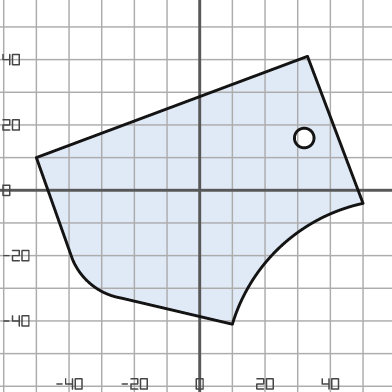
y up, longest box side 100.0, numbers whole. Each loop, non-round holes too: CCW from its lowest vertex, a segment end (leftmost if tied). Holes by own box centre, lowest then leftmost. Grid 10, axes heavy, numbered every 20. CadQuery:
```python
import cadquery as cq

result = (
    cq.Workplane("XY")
    .moveTo(10.0, -41.0)
    .threePointArc((25.0, -17.0), (50.0, -4.0))
    .lineTo(33.0, 41.0)
    .lineTo(-50.0, 10.0)
    .lineTo(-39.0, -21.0)
    .threePointArc((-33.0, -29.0), (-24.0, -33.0))
    .close()
    .moveTo(32.0, 16.0)
    .circle(3.0)
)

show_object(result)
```